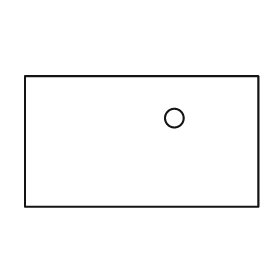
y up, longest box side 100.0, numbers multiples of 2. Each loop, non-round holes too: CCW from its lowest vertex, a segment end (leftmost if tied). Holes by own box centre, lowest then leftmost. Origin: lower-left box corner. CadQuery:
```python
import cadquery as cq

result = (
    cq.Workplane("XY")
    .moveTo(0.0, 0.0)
    .lineTo(100.0, 0.0)
    .lineTo(100.0, 56.0)
    .lineTo(0.0, 56.0)
    .close()
    .moveTo(64.0, 38.0)
    .circle(4.0)
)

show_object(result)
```